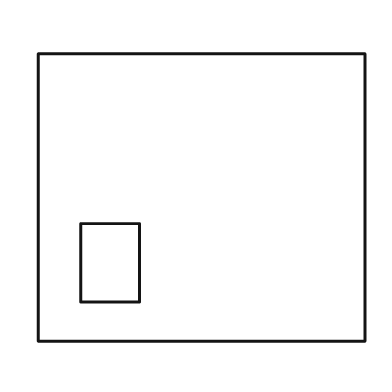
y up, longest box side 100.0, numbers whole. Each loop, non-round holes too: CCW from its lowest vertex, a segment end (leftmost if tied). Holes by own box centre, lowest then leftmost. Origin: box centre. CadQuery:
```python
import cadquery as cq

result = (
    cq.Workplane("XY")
    .moveTo(-50.0, -44.0)
    .lineTo(50.0, -44.0)
    .lineTo(50.0, 44.0)
    .lineTo(-50.0, 44.0)
    .close()
    .moveTo(-37.0, -32.0)
    .lineTo(-19.0, -32.0)
    .lineTo(-19.0, -8.0)
    .lineTo(-37.0, -8.0)
    .close()
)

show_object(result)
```